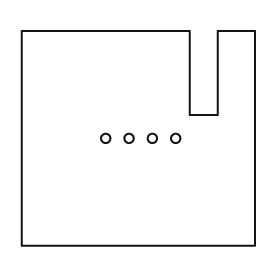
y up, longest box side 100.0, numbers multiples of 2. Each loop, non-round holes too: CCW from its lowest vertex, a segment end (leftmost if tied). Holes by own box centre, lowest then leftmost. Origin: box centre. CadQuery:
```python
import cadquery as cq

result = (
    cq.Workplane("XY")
    .moveTo(-50.0, -46.0)
    .lineTo(50.0, -46.0)
    .lineTo(50.0, 46.0)
    .lineTo(34.0, 46.0)
    .lineTo(34.0, 10.0)
    .lineTo(22.0, 10.0)
    .lineTo(22.0, 46.0)
    .lineTo(-50.0, 46.0)
    .close()
    .moveTo(-14.0, 0.0)
    .circle(2.0)
    .moveTo(-4.0, 0.0)
    .circle(2.0)
    .moveTo(6.0, 0.0)
    .circle(2.0)
    .moveTo(16.0, 0.0)
    .circle(2.0)
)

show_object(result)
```